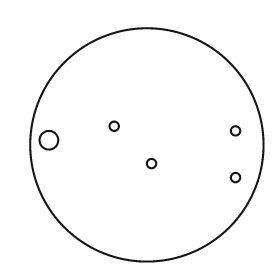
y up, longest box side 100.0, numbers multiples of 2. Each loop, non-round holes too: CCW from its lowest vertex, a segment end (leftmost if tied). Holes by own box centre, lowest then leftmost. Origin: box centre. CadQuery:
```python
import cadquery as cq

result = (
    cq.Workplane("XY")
    .moveTo(0.0, 0.0)
    .circle(50.0)
    .moveTo(38.0, -14.0)
    .circle(2.0)
    .moveTo(2.0, -8.0)
    .circle(2.0)
    .moveTo(-42.0, 2.0)
    .circle(4.0)
    .moveTo(38.0, 6.0)
    .circle(2.0)
    .moveTo(-14.0, 8.0)
    .circle(2.0)
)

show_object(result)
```